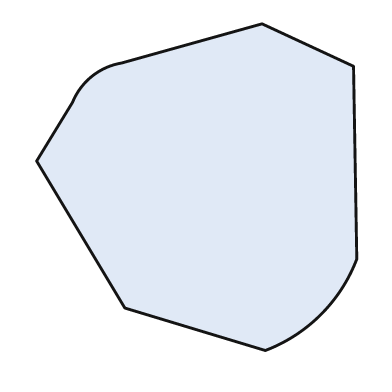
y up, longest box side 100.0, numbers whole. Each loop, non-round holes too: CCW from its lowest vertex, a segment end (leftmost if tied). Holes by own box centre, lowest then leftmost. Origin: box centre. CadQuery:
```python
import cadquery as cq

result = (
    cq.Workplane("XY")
    .moveTo(21.0, -50.0)
    .threePointArc((38.0, -39.0), (49.0, -22.0))
    .lineTo(48.0, 37.0)
    .lineTo(20.0, 50.0)
    .lineTo(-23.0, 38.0)
    .threePointArc((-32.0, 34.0), (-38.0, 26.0))
    .lineTo(-49.0, 8.0)
    .lineTo(-22.0, -37.0)
    .close()
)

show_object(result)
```